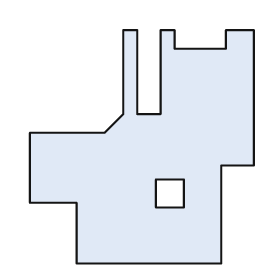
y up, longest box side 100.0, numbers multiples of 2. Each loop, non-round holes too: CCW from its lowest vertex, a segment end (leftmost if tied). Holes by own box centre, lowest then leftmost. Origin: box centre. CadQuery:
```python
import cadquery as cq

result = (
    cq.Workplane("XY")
    .moveTo(-28.0, -50.0)
    .lineTo(34.0, -50.0)
    .lineTo(34.0, -8.0)
    .lineTo(48.0, -8.0)
    .lineTo(48.0, 50.0)
    .lineTo(36.0, 50.0)
    .lineTo(36.0, 42.0)
    .lineTo(14.0, 42.0)
    .lineTo(14.0, 50.0)
    .lineTo(8.0, 50.0)
    .lineTo(8.0, 14.0)
    .lineTo(-2.0, 14.0)
    .lineTo(-2.0, 50.0)
    .lineTo(-8.0, 50.0)
    .lineTo(-8.0, 14.0)
    .lineTo(-16.0, 6.0)
    .lineTo(-48.0, 6.0)
    .lineTo(-48.0, -24.0)
    .lineTo(-28.0, -24.0)
    .close()
    .moveTo(6.0, -26.0)
    .lineTo(18.0, -26.0)
    .lineTo(18.0, -14.0)
    .lineTo(6.0, -14.0)
    .close()
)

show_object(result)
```